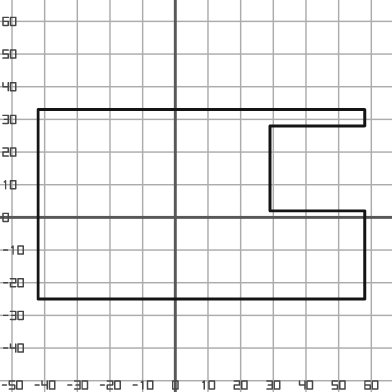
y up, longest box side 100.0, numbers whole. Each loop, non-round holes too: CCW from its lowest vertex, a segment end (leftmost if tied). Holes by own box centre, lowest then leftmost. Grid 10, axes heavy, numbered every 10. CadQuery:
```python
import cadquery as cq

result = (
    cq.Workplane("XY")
    .moveTo(-42.0, -25.0)
    .lineTo(58.0, -25.0)
    .lineTo(58.0, 2.0)
    .lineTo(29.0, 2.0)
    .lineTo(29.0, 28.0)
    .lineTo(58.0, 28.0)
    .lineTo(58.0, 33.0)
    .lineTo(-42.0, 33.0)
    .close()
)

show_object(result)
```